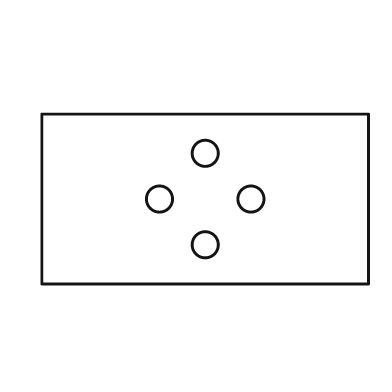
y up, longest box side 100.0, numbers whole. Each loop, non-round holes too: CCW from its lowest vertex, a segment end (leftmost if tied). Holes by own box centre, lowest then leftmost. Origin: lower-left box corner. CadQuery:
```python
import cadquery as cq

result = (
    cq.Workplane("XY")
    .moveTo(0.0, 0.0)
    .lineTo(100.0, 0.0)
    .lineTo(100.0, 52.0)
    .lineTo(0.0, 52.0)
    .close()
    .moveTo(50.0, 12.0)
    .circle(4.0)
    .moveTo(36.0, 26.0)
    .circle(4.0)
    .moveTo(64.0, 26.0)
    .circle(4.0)
    .moveTo(50.0, 40.0)
    .circle(4.0)
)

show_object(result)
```